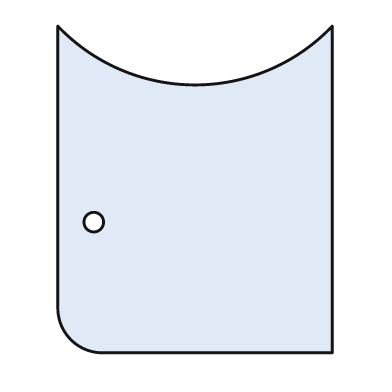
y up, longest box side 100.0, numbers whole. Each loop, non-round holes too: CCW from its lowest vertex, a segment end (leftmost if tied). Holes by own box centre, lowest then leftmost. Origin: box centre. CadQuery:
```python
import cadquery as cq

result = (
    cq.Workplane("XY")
    .moveTo(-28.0, -50.0)
    .lineTo(42.0, -50.0)
    .lineTo(42.0, 50.0)
    .threePointArc((0.0, 32.0), (-42.0, 50.0))
    .lineTo(-42.0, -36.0)
    .threePointArc((-38.0, -46.0), (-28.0, -50.0))
    .close()
    .moveTo(-31.0, -10.0)
    .circle(3.0)
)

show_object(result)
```